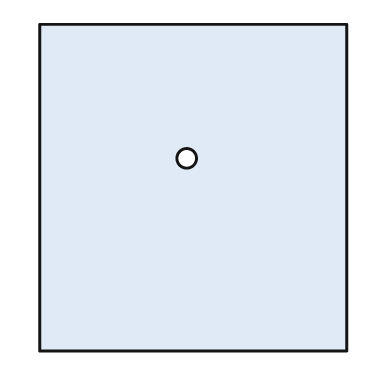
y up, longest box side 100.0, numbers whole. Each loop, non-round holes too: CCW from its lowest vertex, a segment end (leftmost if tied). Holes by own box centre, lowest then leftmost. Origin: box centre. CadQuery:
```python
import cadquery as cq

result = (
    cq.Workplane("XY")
    .moveTo(-47.0, -50.0)
    .lineTo(47.0, -50.0)
    .lineTo(47.0, 50.0)
    .lineTo(-47.0, 50.0)
    .close()
    .moveTo(-2.0, 9.0)
    .circle(3.0)
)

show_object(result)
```